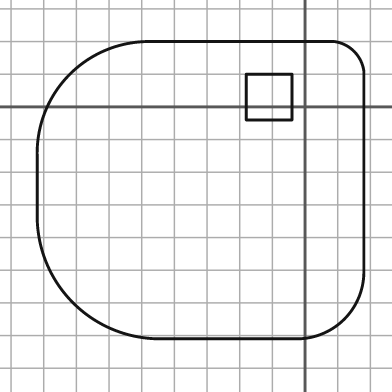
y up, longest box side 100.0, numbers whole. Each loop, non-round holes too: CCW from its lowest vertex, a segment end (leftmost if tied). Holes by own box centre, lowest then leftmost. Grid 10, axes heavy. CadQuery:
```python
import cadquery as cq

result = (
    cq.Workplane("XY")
    .moveTo(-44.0, -71.0)
    .lineTo(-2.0, -71.0)
    .threePointArc((12.0, -65.0), (18.0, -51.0))
    .lineTo(18.0, 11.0)
    .threePointArc((15.0, 17.0), (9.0, 20.0))
    .lineTo(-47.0, 20.0)
    .threePointArc((-72.0, 10.0), (-82.0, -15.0))
    .lineTo(-82.0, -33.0)
    .threePointArc((-71.0, -60.0), (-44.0, -71.0))
    .close()
    .moveTo(-18.0, -4.0)
    .lineTo(-4.0, -4.0)
    .lineTo(-4.0, 10.0)
    .lineTo(-18.0, 10.0)
    .close()
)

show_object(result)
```